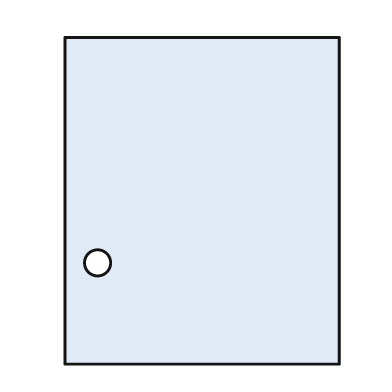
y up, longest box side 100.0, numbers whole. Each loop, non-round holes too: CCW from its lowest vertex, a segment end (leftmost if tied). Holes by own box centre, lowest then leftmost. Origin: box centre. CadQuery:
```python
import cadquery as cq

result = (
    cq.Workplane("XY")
    .moveTo(-42.0, -50.0)
    .lineTo(42.0, -50.0)
    .lineTo(42.0, 50.0)
    .lineTo(-42.0, 50.0)
    .close()
    .moveTo(-32.0, -19.0)
    .circle(4.0)
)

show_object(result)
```